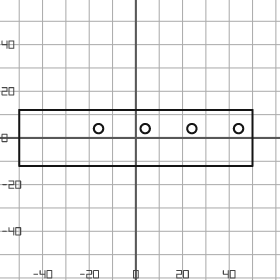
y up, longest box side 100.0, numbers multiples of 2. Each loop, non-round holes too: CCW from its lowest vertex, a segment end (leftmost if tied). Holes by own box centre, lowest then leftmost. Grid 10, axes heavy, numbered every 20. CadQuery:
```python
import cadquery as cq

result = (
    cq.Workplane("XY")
    .moveTo(-50.0, -12.0)
    .lineTo(50.0, -12.0)
    .lineTo(50.0, 12.0)
    .lineTo(-50.0, 12.0)
    .close()
    .moveTo(-16.0, 4.0)
    .circle(2.0)
    .moveTo(4.0, 4.0)
    .circle(2.0)
    .moveTo(24.0, 4.0)
    .circle(2.0)
    .moveTo(44.0, 4.0)
    .circle(2.0)
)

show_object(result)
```